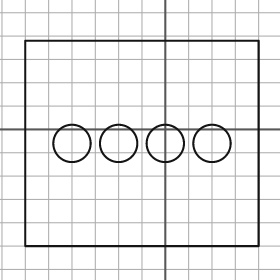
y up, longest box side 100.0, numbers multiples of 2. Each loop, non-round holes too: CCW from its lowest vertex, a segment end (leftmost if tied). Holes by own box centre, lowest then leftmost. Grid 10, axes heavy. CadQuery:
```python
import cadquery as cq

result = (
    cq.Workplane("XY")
    .moveTo(-60.0, -50.0)
    .lineTo(40.0, -50.0)
    .lineTo(40.0, 38.0)
    .lineTo(-60.0, 38.0)
    .close()
    .moveTo(-40.0, -6.0)
    .circle(8.0)
    .moveTo(-20.0, -6.0)
    .circle(8.0)
    .moveTo(0.0, -6.0)
    .circle(8.0)
    .moveTo(20.0, -6.0)
    .circle(8.0)
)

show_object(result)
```